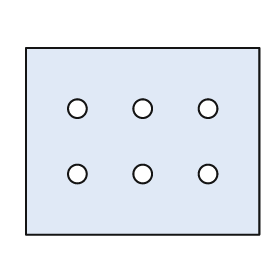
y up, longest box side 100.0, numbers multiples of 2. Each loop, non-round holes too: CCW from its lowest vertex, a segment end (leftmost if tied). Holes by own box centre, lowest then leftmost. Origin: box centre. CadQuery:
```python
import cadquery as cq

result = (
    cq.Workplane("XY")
    .moveTo(-50.0, -40.0)
    .lineTo(50.0, -40.0)
    .lineTo(50.0, 40.0)
    .lineTo(-50.0, 40.0)
    .close()
    .moveTo(-28.0, -14.0)
    .circle(4.0)
    .moveTo(0.0, -14.0)
    .circle(4.0)
    .moveTo(28.0, -14.0)
    .circle(4.0)
    .moveTo(-28.0, 14.0)
    .circle(4.0)
    .moveTo(0.0, 14.0)
    .circle(4.0)
    .moveTo(28.0, 14.0)
    .circle(4.0)
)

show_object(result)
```